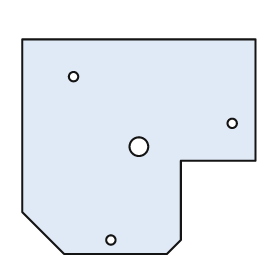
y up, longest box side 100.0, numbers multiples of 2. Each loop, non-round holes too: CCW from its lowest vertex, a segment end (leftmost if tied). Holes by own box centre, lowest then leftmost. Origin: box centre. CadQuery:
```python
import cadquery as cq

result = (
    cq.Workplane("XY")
    .moveTo(-32.0, -46.0)
    .lineTo(12.0, -46.0)
    .lineTo(18.0, -40.0)
    .lineTo(18.0, -6.0)
    .lineTo(50.0, -6.0)
    .lineTo(50.0, 46.0)
    .lineTo(-50.0, 46.0)
    .lineTo(-50.0, -28.0)
    .close()
    .moveTo(-12.0, -40.0)
    .circle(2.0)
    .moveTo(0.0, 0.0)
    .circle(4.0)
    .moveTo(40.0, 10.0)
    .circle(2.0)
    .moveTo(-28.0, 30.0)
    .circle(2.0)
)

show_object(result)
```